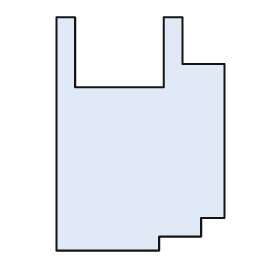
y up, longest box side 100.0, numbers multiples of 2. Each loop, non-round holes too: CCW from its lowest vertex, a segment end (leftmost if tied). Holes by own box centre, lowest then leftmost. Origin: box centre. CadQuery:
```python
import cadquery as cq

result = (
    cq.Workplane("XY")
    .moveTo(-36.0, -50.0)
    .lineTo(8.0, -50.0)
    .lineTo(8.0, -44.0)
    .lineTo(26.0, -44.0)
    .lineTo(26.0, -36.0)
    .lineTo(36.0, -36.0)
    .lineTo(36.0, 30.0)
    .lineTo(18.0, 30.0)
    .lineTo(18.0, 50.0)
    .lineTo(10.0, 50.0)
    .lineTo(10.0, 20.0)
    .lineTo(-28.0, 20.0)
    .lineTo(-28.0, 50.0)
    .lineTo(-36.0, 50.0)
    .close()
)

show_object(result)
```